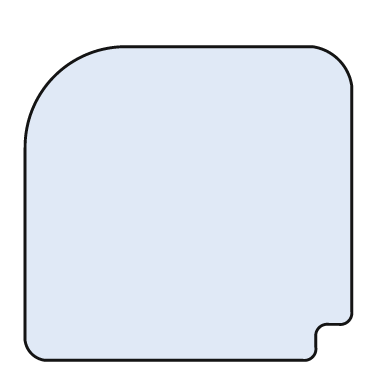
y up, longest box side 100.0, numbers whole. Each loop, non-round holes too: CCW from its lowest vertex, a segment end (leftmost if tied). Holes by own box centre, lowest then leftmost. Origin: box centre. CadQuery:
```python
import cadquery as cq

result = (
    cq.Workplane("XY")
    .moveTo(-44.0, -48.0)
    .lineTo(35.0, -48.0)
    .threePointArc((38.0, -47.0), (39.0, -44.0))
    .lineTo(39.0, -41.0)
    .threePointArc((40.0, -38.0), (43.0, -37.0))
    .lineTo(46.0, -37.0)
    .threePointArc((49.0, -36.0), (50.0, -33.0))
    .lineTo(50.0, 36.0)
    .threePointArc((46.0, 44.0), (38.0, 48.0))
    .lineTo(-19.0, 48.0)
    .threePointArc((-41.0, 39.0), (-50.0, 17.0))
    .lineTo(-50.0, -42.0)
    .threePointArc((-48.0, -46.0), (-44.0, -48.0))
    .close()
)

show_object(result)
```